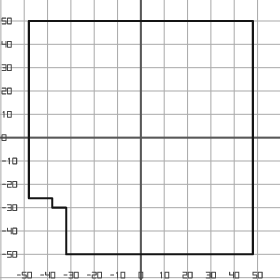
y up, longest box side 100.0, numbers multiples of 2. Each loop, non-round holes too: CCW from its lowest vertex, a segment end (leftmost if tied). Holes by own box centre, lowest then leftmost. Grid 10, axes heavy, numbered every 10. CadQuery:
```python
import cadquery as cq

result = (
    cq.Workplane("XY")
    .moveTo(-32.0, -50.0)
    .lineTo(48.0, -50.0)
    .lineTo(48.0, 50.0)
    .lineTo(-48.0, 50.0)
    .lineTo(-48.0, -26.0)
    .lineTo(-38.0, -26.0)
    .lineTo(-38.0, -30.0)
    .lineTo(-32.0, -30.0)
    .close()
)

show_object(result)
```